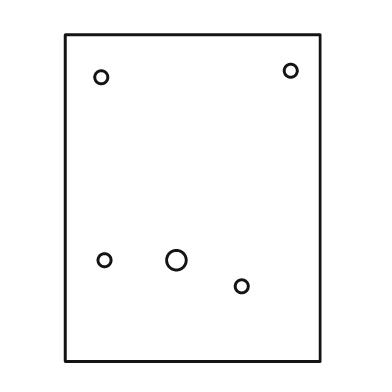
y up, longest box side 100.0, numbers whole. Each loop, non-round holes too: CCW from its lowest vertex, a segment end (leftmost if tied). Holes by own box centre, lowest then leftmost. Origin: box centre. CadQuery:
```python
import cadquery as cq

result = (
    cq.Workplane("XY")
    .moveTo(-39.0, -50.0)
    .lineTo(39.0, -50.0)
    .lineTo(39.0, 50.0)
    .lineTo(-39.0, 50.0)
    .close()
    .moveTo(15.0, -27.0)
    .circle(2.0)
    .moveTo(-27.0, -19.0)
    .circle(2.0)
    .moveTo(-5.0, -19.0)
    .circle(3.0)
    .moveTo(-28.0, 37.0)
    .circle(2.0)
    .moveTo(30.0, 39.0)
    .circle(2.0)
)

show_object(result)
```